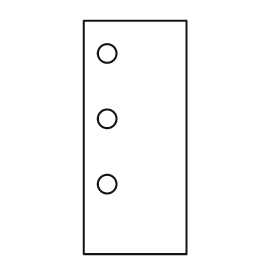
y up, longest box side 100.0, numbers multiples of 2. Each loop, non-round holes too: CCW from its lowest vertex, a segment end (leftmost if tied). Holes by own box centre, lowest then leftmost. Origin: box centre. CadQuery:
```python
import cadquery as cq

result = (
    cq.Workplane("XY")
    .moveTo(-22.0, -50.0)
    .lineTo(22.0, -50.0)
    .lineTo(22.0, 50.0)
    .lineTo(-22.0, 50.0)
    .close()
    .moveTo(-12.0, -20.0)
    .circle(4.0)
    .moveTo(-12.0, 8.0)
    .circle(4.0)
    .moveTo(-12.0, 36.0)
    .circle(4.0)
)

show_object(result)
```